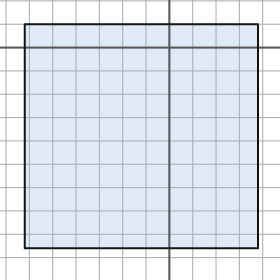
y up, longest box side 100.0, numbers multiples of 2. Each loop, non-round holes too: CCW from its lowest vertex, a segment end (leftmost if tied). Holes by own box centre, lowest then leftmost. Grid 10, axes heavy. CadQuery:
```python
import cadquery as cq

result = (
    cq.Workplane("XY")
    .moveTo(-62.0, -86.0)
    .lineTo(38.0, -86.0)
    .lineTo(38.0, 10.0)
    .lineTo(-62.0, 10.0)
    .close()
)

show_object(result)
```